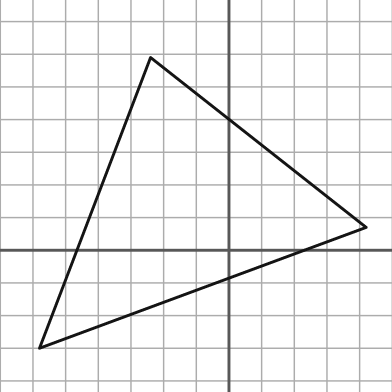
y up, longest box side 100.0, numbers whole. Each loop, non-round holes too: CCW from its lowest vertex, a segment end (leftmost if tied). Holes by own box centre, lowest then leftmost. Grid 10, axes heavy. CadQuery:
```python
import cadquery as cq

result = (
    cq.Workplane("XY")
    .moveTo(-58.0, -30.0)
    .lineTo(42.0, 7.0)
    .lineTo(-24.0, 59.0)
    .close()
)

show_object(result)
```